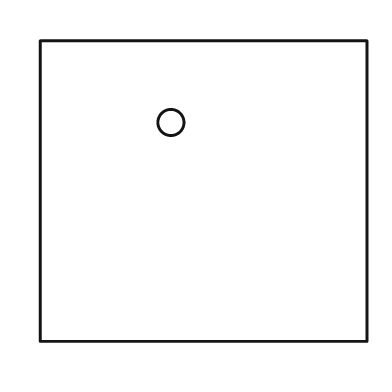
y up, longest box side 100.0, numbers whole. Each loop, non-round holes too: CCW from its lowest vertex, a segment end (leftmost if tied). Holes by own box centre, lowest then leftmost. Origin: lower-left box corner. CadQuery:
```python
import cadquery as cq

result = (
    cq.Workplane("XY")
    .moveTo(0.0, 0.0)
    .lineTo(100.0, 0.0)
    .lineTo(100.0, 92.0)
    .lineTo(0.0, 92.0)
    .close()
    .moveTo(40.0, 67.0)
    .circle(4.0)
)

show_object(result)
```